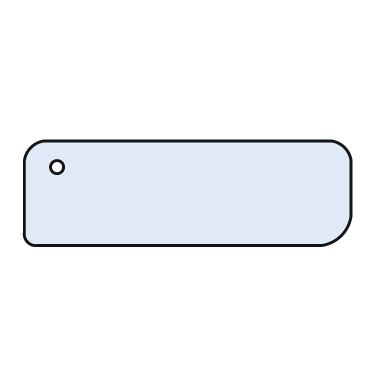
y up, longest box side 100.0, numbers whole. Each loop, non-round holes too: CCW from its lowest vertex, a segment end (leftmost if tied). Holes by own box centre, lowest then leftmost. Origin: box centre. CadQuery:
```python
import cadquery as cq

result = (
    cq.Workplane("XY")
    .moveTo(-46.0, -16.0)
    .lineTo(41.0, -16.0)
    .threePointArc((47.0, -13.0), (50.0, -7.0))
    .lineTo(50.0, 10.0)
    .threePointArc((48.0, 14.0), (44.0, 16.0))
    .lineTo(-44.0, 16.0)
    .threePointArc((-48.0, 14.0), (-50.0, 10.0))
    .lineTo(-50.0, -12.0)
    .threePointArc((-49.0, -15.0), (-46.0, -16.0))
    .close()
    .moveTo(-40.0, 8.0)
    .circle(2.0)
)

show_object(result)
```